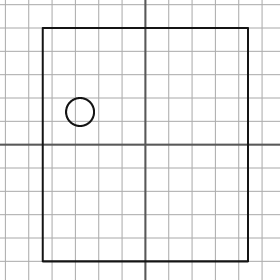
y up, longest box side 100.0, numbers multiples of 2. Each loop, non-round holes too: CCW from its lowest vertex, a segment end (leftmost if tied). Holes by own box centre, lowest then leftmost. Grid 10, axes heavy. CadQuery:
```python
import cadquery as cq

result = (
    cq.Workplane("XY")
    .moveTo(-44.0, -50.0)
    .lineTo(44.0, -50.0)
    .lineTo(44.0, 50.0)
    .lineTo(-44.0, 50.0)
    .close()
    .moveTo(-28.0, 14.0)
    .circle(6.0)
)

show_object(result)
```